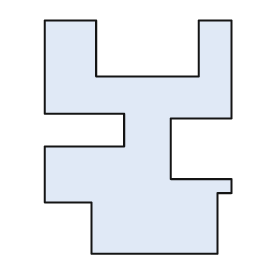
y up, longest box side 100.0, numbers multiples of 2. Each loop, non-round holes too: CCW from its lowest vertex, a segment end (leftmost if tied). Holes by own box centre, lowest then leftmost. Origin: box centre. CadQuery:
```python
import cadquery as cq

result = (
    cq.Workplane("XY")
    .moveTo(-20.0, -50.0)
    .lineTo(34.0, -50.0)
    .lineTo(34.0, -24.0)
    .lineTo(40.0, -24.0)
    .lineTo(40.0, -18.0)
    .lineTo(14.0, -18.0)
    .lineTo(14.0, 8.0)
    .lineTo(40.0, 8.0)
    .lineTo(40.0, 50.0)
    .lineTo(26.0, 50.0)
    .lineTo(26.0, 26.0)
    .lineTo(-18.0, 26.0)
    .lineTo(-18.0, 50.0)
    .lineTo(-40.0, 50.0)
    .lineTo(-40.0, 10.0)
    .lineTo(-6.0, 10.0)
    .lineTo(-6.0, -4.0)
    .lineTo(-40.0, -4.0)
    .lineTo(-40.0, -28.0)
    .lineTo(-20.0, -28.0)
    .close()
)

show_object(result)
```